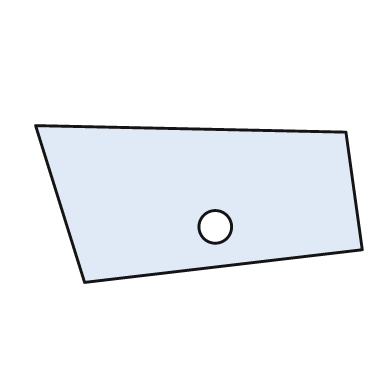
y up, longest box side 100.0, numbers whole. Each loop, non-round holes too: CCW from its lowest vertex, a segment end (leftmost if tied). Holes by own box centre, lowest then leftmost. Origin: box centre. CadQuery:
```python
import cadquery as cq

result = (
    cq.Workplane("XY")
    .moveTo(-35.0, -24.0)
    .lineTo(50.0, -14.0)
    .lineTo(45.0, 22.0)
    .lineTo(-50.0, 24.0)
    .close()
    .moveTo(5.0, -7.0)
    .circle(5.0)
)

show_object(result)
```